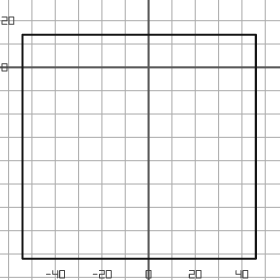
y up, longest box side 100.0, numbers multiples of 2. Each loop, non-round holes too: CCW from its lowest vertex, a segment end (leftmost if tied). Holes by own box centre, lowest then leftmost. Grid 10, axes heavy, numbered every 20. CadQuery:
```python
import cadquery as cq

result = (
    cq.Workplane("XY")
    .moveTo(-54.0, -82.0)
    .lineTo(46.0, -82.0)
    .lineTo(46.0, 14.0)
    .lineTo(-54.0, 14.0)
    .close()
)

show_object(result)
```